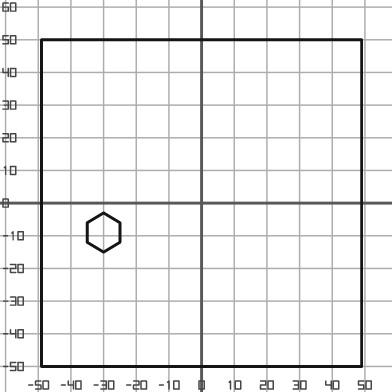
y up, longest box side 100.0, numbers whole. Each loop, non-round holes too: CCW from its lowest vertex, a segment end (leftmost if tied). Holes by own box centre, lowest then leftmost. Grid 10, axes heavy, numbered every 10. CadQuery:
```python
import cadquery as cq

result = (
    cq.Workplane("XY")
    .moveTo(-49.0, -50.0)
    .lineTo(49.0, -50.0)
    .lineTo(49.0, 50.0)
    .lineTo(-49.0, 50.0)
    .close()
    .moveTo(-30.0, -15.0)
    .lineTo(-25.0, -12.0)
    .lineTo(-25.0, -6.0)
    .lineTo(-30.0, -3.0)
    .lineTo(-35.0, -6.0)
    .lineTo(-35.0, -12.0)
    .close()
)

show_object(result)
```